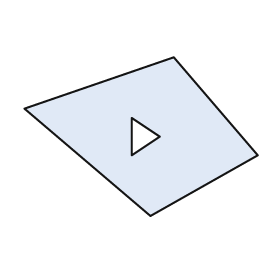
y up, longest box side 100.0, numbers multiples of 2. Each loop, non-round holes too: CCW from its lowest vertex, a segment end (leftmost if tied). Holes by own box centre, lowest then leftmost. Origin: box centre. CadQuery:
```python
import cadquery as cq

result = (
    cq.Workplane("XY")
    .moveTo(4.0, -34.0)
    .lineTo(50.0, -8.0)
    .lineTo(14.0, 34.0)
    .lineTo(-50.0, 12.0)
    .close()
    .moveTo(-4.0, -8.0)
    .lineTo(8.0, 0.0)
    .lineTo(-4.0, 8.0)
    .close()
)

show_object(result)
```